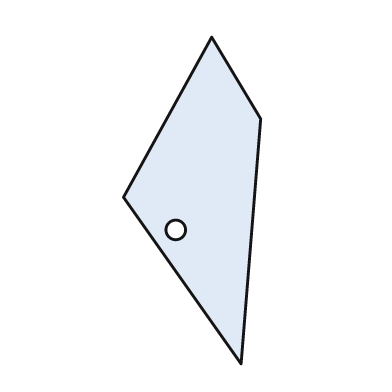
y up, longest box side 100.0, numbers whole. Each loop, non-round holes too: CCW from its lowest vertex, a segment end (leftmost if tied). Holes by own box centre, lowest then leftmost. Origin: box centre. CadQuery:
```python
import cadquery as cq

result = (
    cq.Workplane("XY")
    .moveTo(15.0, -50.0)
    .lineTo(21.0, 25.0)
    .lineTo(6.0, 50.0)
    .lineTo(-21.0, 1.0)
    .close()
    .moveTo(-5.0, -9.0)
    .circle(3.0)
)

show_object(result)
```